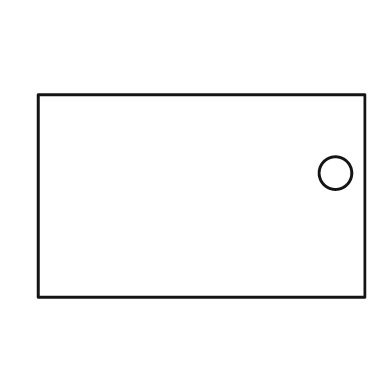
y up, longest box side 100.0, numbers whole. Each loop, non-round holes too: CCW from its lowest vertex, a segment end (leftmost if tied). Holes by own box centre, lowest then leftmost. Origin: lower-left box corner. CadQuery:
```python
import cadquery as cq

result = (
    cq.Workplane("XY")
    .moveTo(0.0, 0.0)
    .lineTo(100.0, 0.0)
    .lineTo(100.0, 62.0)
    .lineTo(0.0, 62.0)
    .close()
    .moveTo(91.0, 38.0)
    .circle(5.0)
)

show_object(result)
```